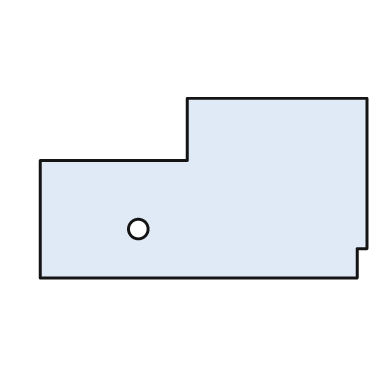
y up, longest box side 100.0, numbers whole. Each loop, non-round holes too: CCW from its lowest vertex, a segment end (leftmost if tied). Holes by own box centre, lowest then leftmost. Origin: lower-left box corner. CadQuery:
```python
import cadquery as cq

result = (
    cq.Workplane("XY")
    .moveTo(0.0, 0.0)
    .lineTo(97.0, 0.0)
    .lineTo(97.0, 9.0)
    .lineTo(100.0, 9.0)
    .lineTo(100.0, 55.0)
    .lineTo(45.0, 55.0)
    .lineTo(45.0, 36.0)
    .lineTo(0.0, 36.0)
    .close()
    .moveTo(30.0, 15.0)
    .circle(3.0)
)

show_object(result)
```